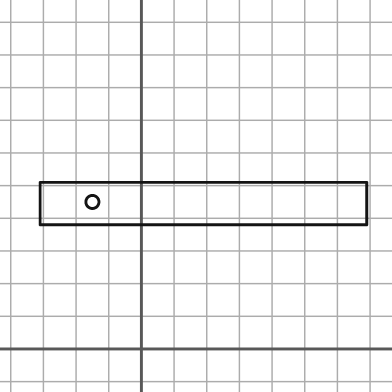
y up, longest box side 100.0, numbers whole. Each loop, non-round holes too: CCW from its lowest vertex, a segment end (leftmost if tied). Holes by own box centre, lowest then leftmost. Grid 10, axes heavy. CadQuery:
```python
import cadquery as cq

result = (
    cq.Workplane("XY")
    .moveTo(-31.0, 38.0)
    .lineTo(69.0, 38.0)
    .lineTo(69.0, 51.0)
    .lineTo(-31.0, 51.0)
    .close()
    .moveTo(-15.0, 45.0)
    .circle(2.0)
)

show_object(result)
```